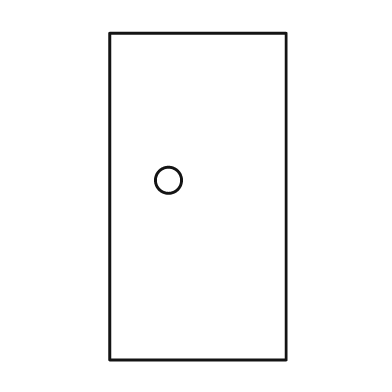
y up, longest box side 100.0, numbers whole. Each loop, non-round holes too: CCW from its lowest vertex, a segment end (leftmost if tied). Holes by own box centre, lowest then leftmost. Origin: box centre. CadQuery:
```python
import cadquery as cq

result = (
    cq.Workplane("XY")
    .moveTo(-27.0, -50.0)
    .lineTo(27.0, -50.0)
    .lineTo(27.0, 50.0)
    .lineTo(-27.0, 50.0)
    .close()
    .moveTo(-9.0, 5.0)
    .circle(4.0)
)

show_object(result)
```